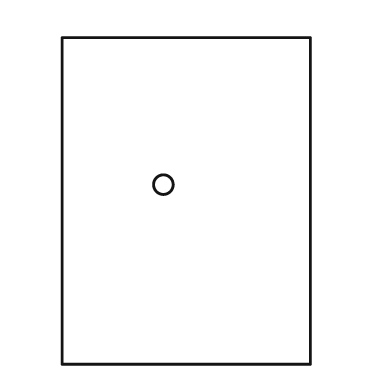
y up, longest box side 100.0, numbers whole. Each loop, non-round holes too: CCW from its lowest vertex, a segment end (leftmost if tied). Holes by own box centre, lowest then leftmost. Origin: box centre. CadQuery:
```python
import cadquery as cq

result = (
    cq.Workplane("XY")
    .moveTo(-38.0, -50.0)
    .lineTo(38.0, -50.0)
    .lineTo(38.0, 50.0)
    .lineTo(-38.0, 50.0)
    .close()
    .moveTo(-7.0, 5.0)
    .circle(3.0)
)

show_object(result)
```